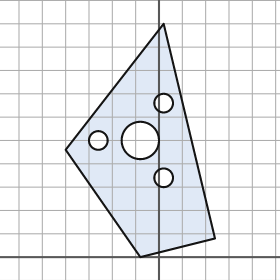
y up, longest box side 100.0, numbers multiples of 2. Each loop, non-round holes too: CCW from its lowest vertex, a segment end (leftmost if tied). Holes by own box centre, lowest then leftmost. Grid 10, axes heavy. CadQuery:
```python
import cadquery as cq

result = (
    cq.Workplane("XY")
    .moveTo(-8.0, 0.0)
    .lineTo(24.0, 8.0)
    .lineTo(2.0, 100.0)
    .lineTo(-40.0, 46.0)
    .close()
    .moveTo(2.0, 34.0)
    .circle(4.0)
    .moveTo(-26.0, 50.0)
    .circle(4.0)
    .moveTo(-8.0, 50.0)
    .circle(8.0)
    .moveTo(2.0, 66.0)
    .circle(4.0)
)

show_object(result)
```